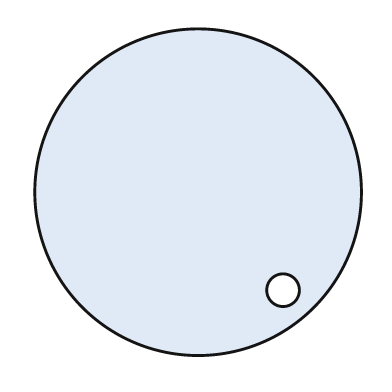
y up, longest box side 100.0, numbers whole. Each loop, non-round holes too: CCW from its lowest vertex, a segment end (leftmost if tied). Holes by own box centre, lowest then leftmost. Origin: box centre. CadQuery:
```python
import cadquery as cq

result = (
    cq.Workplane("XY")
    .moveTo(0.0, 0.0)
    .circle(50.0)
    .moveTo(26.0, -30.0)
    .circle(5.0)
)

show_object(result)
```